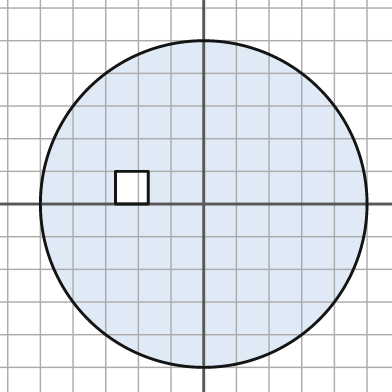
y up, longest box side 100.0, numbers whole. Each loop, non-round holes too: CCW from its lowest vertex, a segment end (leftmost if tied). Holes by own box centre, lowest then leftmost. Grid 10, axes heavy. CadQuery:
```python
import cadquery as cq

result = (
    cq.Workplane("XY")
    .moveTo(0.0, 0.0)
    .circle(50.0)
    .moveTo(-27.0, 0.0)
    .lineTo(-17.0, 0.0)
    .lineTo(-17.0, 10.0)
    .lineTo(-27.0, 10.0)
    .close()
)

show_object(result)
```